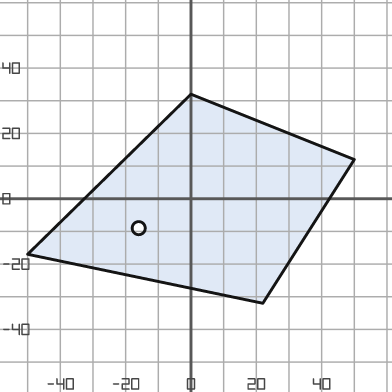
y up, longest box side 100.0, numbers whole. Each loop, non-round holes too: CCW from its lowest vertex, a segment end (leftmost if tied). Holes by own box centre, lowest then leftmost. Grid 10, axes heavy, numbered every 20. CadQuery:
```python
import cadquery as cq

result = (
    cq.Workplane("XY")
    .moveTo(22.0, -32.0)
    .lineTo(50.0, 12.0)
    .lineTo(0.0, 32.0)
    .lineTo(-50.0, -17.0)
    .close()
    .moveTo(-16.0, -9.0)
    .circle(2.0)
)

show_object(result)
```